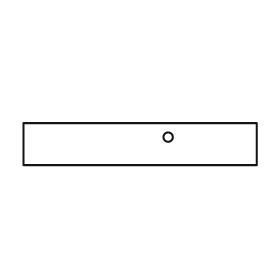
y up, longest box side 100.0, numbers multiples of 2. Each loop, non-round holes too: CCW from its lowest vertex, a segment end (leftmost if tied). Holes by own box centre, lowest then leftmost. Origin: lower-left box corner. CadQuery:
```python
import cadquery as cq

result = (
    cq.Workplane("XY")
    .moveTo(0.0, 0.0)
    .lineTo(100.0, 0.0)
    .lineTo(100.0, 18.0)
    .lineTo(0.0, 18.0)
    .close()
    .moveTo(62.0, 12.0)
    .circle(2.0)
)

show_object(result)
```